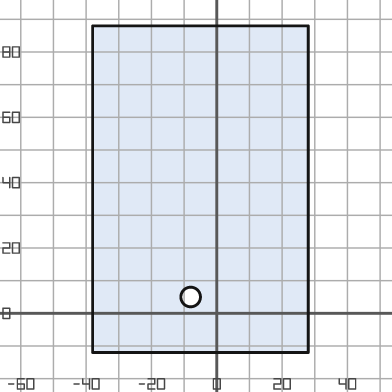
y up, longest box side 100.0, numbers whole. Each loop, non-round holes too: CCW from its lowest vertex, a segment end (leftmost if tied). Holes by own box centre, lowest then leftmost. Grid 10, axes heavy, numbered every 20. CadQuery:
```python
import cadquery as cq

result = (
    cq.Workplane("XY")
    .moveTo(-38.0, -12.0)
    .lineTo(28.0, -12.0)
    .lineTo(28.0, 88.0)
    .lineTo(-38.0, 88.0)
    .close()
    .moveTo(-8.0, 5.0)
    .circle(3.0)
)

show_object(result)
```